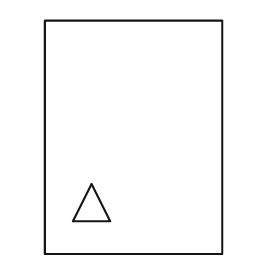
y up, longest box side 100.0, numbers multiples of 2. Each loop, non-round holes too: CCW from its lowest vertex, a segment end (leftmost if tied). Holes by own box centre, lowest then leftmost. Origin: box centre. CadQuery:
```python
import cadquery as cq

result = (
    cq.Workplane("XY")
    .moveTo(-38.0, -50.0)
    .lineTo(38.0, -50.0)
    .lineTo(38.0, 50.0)
    .lineTo(-38.0, 50.0)
    .close()
    .moveTo(-26.0, -36.0)
    .lineTo(-10.0, -36.0)
    .lineTo(-18.0, -20.0)
    .close()
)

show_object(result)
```